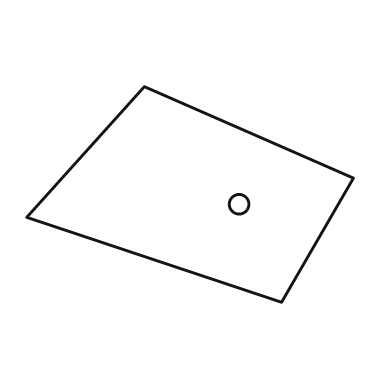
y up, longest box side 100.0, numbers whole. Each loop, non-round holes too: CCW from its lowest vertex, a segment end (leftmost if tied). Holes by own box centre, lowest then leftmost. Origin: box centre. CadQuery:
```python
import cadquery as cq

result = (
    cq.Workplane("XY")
    .moveTo(28.0, -33.0)
    .lineTo(50.0, 5.0)
    .lineTo(-14.0, 33.0)
    .lineTo(-50.0, -7.0)
    .close()
    .moveTo(15.0, -3.0)
    .circle(3.0)
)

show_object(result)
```